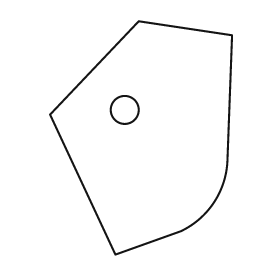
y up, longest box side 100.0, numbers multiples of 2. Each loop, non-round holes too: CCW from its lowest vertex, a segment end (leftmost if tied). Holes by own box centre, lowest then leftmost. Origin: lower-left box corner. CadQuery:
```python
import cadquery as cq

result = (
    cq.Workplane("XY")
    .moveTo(28.0, 0.0)
    .lineTo(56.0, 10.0)
    .threePointArc((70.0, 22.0), (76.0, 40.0))
    .lineTo(78.0, 94.0)
    .lineTo(38.0, 100.0)
    .lineTo(0.0, 60.0)
    .close()
    .moveTo(32.0, 62.0)
    .circle(6.0)
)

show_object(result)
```